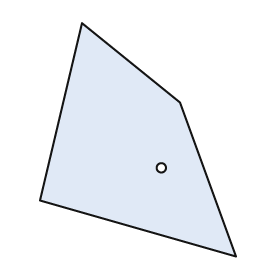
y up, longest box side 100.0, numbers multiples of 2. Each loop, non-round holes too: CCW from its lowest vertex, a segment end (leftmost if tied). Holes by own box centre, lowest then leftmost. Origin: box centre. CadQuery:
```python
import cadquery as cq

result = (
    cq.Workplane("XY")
    .moveTo(42.0, -50.0)
    .lineTo(18.0, 16.0)
    .lineTo(-24.0, 50.0)
    .lineTo(-42.0, -26.0)
    .close()
    .moveTo(10.0, -12.0)
    .circle(2.0)
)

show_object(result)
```